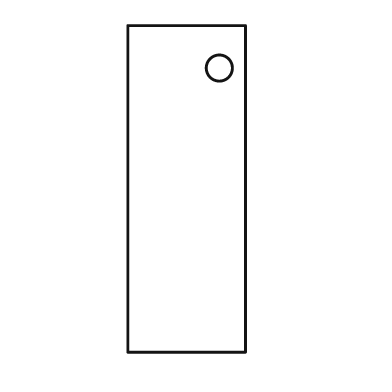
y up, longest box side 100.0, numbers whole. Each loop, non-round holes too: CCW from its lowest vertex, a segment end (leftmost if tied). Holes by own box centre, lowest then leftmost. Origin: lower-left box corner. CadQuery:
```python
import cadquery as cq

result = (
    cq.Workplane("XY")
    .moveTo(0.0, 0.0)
    .lineTo(36.0, 0.0)
    .lineTo(36.0, 100.0)
    .lineTo(0.0, 100.0)
    .close()
    .moveTo(28.0, 87.0)
    .circle(4.0)
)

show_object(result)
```